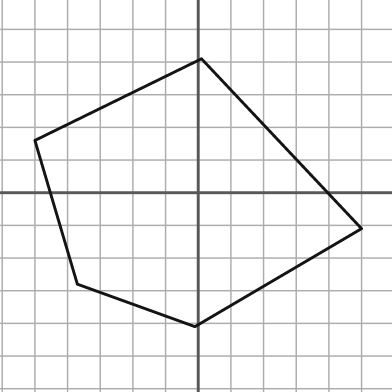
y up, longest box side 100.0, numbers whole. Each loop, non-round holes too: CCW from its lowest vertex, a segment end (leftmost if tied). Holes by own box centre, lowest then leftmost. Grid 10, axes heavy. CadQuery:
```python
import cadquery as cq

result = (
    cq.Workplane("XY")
    .moveTo(-1.0, -41.0)
    .lineTo(50.0, -11.0)
    .lineTo(1.0, 41.0)
    .lineTo(-50.0, 16.0)
    .lineTo(-37.0, -28.0)
    .close()
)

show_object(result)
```